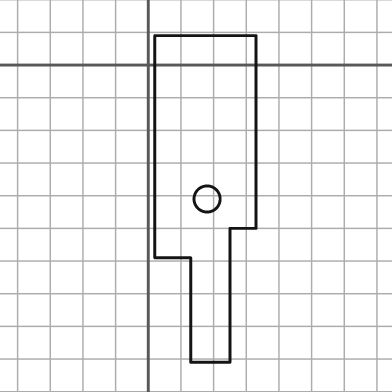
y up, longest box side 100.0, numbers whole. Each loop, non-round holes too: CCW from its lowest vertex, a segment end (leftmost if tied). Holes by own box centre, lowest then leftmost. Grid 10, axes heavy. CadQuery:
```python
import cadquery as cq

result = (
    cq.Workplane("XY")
    .moveTo(13.0, -91.0)
    .lineTo(25.0, -91.0)
    .lineTo(25.0, -50.0)
    .lineTo(33.0, -50.0)
    .lineTo(33.0, 9.0)
    .lineTo(2.0, 9.0)
    .lineTo(2.0, -59.0)
    .lineTo(13.0, -59.0)
    .close()
    .moveTo(18.0, -41.0)
    .circle(4.0)
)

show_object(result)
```